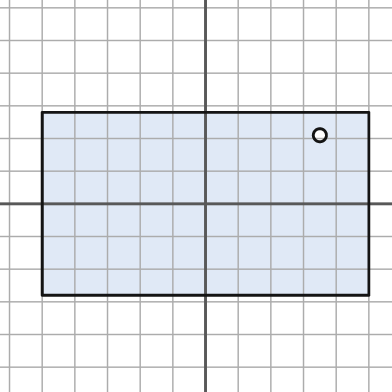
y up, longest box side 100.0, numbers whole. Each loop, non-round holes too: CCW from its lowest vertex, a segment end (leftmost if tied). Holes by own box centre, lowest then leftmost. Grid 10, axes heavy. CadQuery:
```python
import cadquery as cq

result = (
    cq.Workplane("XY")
    .moveTo(-50.0, -28.0)
    .lineTo(50.0, -28.0)
    .lineTo(50.0, 28.0)
    .lineTo(-50.0, 28.0)
    .close()
    .moveTo(35.0, 21.0)
    .circle(2.0)
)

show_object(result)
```